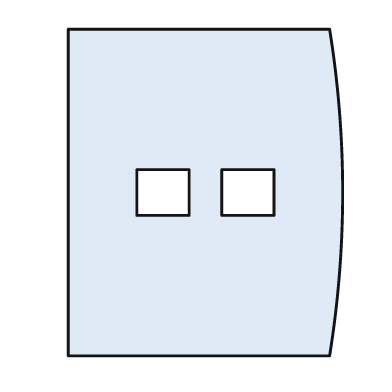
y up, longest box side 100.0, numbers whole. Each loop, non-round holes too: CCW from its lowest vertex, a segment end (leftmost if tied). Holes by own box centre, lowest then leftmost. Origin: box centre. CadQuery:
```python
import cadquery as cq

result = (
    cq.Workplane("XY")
    .moveTo(-42.0, -50.0)
    .lineTo(38.0, -50.0)
    .threePointArc((42.0, 0.0), (38.0, 50.0))
    .lineTo(-42.0, 50.0)
    .close()
    .moveTo(-21.0, -7.0)
    .lineTo(-5.0, -7.0)
    .lineTo(-5.0, 7.0)
    .lineTo(-21.0, 7.0)
    .close()
    .moveTo(5.0, -7.0)
    .lineTo(21.0, -7.0)
    .lineTo(21.0, 7.0)
    .lineTo(5.0, 7.0)
    .close()
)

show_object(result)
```